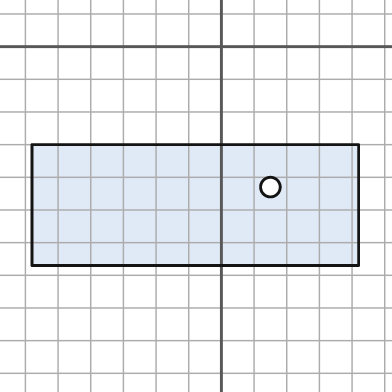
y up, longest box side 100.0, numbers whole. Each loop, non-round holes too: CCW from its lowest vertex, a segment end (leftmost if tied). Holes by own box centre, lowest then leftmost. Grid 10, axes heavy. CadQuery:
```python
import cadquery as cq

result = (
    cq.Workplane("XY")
    .moveTo(-58.0, -67.0)
    .lineTo(42.0, -67.0)
    .lineTo(42.0, -30.0)
    .lineTo(-58.0, -30.0)
    .close()
    .moveTo(15.0, -43.0)
    .circle(3.0)
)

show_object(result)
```